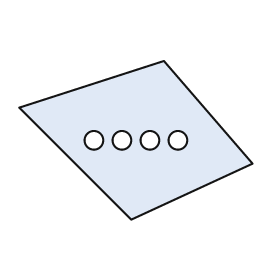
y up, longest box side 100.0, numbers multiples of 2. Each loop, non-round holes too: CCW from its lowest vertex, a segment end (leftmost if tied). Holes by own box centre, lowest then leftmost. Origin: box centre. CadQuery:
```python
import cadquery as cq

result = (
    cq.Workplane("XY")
    .moveTo(-2.0, -34.0)
    .lineTo(50.0, -10.0)
    .lineTo(12.0, 34.0)
    .lineTo(-50.0, 14.0)
    .close()
    .moveTo(-18.0, 0.0)
    .circle(4.0)
    .moveTo(-6.0, 0.0)
    .circle(4.0)
    .moveTo(6.0, 0.0)
    .circle(4.0)
    .moveTo(18.0, 0.0)
    .circle(4.0)
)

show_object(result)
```